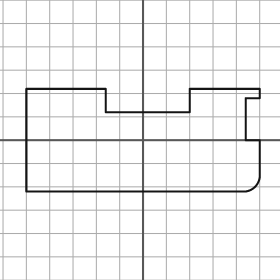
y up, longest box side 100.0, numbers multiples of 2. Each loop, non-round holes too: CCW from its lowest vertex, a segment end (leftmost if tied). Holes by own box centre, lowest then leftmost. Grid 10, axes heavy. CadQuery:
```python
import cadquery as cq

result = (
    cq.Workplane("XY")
    .moveTo(-50.0, -22.0)
    .lineTo(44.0, -22.0)
    .threePointArc((48.0, -20.0), (50.0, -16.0))
    .lineTo(50.0, 0.0)
    .lineTo(44.0, 0.0)
    .lineTo(44.0, 18.0)
    .lineTo(50.0, 18.0)
    .lineTo(50.0, 22.0)
    .lineTo(20.0, 22.0)
    .lineTo(20.0, 12.0)
    .lineTo(-16.0, 12.0)
    .lineTo(-16.0, 22.0)
    .lineTo(-50.0, 22.0)
    .close()
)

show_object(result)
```